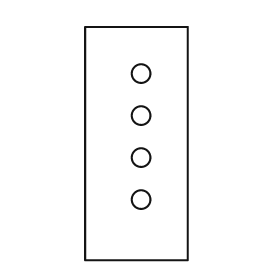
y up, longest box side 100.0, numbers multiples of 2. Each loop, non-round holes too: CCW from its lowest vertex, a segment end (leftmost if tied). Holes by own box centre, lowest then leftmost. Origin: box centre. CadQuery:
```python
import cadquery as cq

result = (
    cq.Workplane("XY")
    .moveTo(-22.0, -50.0)
    .lineTo(22.0, -50.0)
    .lineTo(22.0, 50.0)
    .lineTo(-22.0, 50.0)
    .close()
    .moveTo(2.0, -24.0)
    .circle(4.0)
    .moveTo(2.0, -6.0)
    .circle(4.0)
    .moveTo(2.0, 12.0)
    .circle(4.0)
    .moveTo(2.0, 30.0)
    .circle(4.0)
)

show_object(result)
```